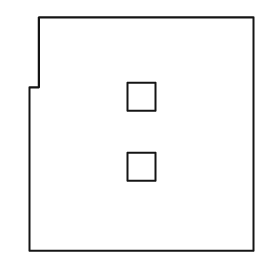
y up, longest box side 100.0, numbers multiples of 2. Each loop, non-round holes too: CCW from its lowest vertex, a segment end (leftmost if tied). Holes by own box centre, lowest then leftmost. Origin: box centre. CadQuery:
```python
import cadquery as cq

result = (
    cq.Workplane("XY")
    .moveTo(-48.0, -50.0)
    .lineTo(48.0, -50.0)
    .lineTo(48.0, 50.0)
    .lineTo(-44.0, 50.0)
    .lineTo(-44.0, 20.0)
    .lineTo(-48.0, 20.0)
    .close()
    .moveTo(-6.0, -20.0)
    .lineTo(6.0, -20.0)
    .lineTo(6.0, -8.0)
    .lineTo(-6.0, -8.0)
    .close()
    .moveTo(-6.0, 10.0)
    .lineTo(6.0, 10.0)
    .lineTo(6.0, 22.0)
    .lineTo(-6.0, 22.0)
    .close()
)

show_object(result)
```